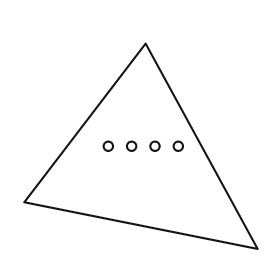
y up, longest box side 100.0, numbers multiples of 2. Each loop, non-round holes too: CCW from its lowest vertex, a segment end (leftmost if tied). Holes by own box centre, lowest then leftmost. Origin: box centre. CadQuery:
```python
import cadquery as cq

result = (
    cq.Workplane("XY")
    .moveTo(50.0, -44.0)
    .lineTo(2.0, 44.0)
    .lineTo(-50.0, -24.0)
    .close()
    .moveTo(-14.0, 0.0)
    .circle(2.0)
    .moveTo(-4.0, 0.0)
    .circle(2.0)
    .moveTo(6.0, 0.0)
    .circle(2.0)
    .moveTo(16.0, 0.0)
    .circle(2.0)
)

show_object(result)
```